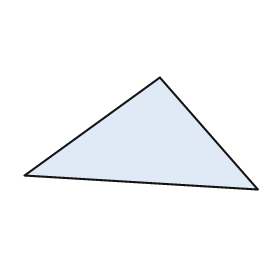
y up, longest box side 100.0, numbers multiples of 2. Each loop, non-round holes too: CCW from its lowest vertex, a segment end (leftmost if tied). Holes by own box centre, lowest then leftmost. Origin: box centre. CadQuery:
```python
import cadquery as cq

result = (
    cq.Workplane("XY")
    .moveTo(50.0, -24.0)
    .lineTo(8.0, 24.0)
    .lineTo(-50.0, -18.0)
    .close()
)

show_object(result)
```